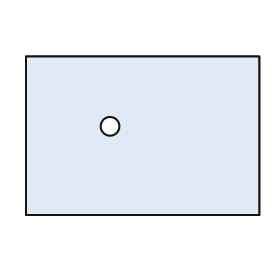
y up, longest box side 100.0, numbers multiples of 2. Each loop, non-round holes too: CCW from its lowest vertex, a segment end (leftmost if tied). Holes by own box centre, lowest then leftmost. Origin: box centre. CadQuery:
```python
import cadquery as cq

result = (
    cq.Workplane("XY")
    .moveTo(-50.0, -34.0)
    .lineTo(50.0, -34.0)
    .lineTo(50.0, 34.0)
    .lineTo(-50.0, 34.0)
    .close()
    .moveTo(-14.0, 4.0)
    .circle(4.0)
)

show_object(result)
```